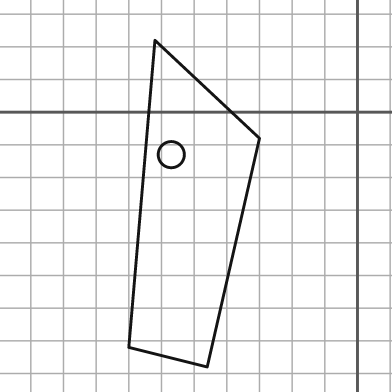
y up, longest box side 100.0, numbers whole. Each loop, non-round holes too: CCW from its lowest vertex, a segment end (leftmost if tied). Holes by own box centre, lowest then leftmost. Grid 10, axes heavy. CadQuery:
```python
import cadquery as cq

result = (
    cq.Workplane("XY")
    .moveTo(-46.0, -78.0)
    .lineTo(-30.0, -8.0)
    .lineTo(-62.0, 22.0)
    .lineTo(-70.0, -72.0)
    .close()
    .moveTo(-57.0, -13.0)
    .circle(4.0)
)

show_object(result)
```